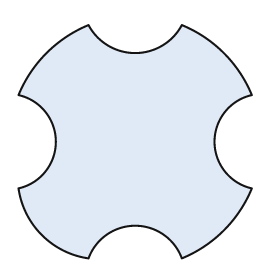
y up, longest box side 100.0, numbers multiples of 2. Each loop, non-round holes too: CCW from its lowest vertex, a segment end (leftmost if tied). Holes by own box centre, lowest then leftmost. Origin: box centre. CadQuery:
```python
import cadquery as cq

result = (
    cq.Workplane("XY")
    .moveTo(-20.0, -50.0)
    .threePointArc((0.0, -36.0), (20.0, -50.0))
    .threePointArc((38.0, -38.0), (50.0, -20.0))
    .threePointArc((34.0, 0.0), (50.0, 20.0))
    .threePointArc((38.0, 38.0), (20.0, 50.0))
    .threePointArc((0.0, 38.0), (-20.0, 50.0))
    .threePointArc((-38.0, 38.0), (-50.0, 20.0))
    .threePointArc((-34.0, 0.0), (-50.0, -20.0))
    .threePointArc((-40.0, -40.0), (-20.0, -50.0))
    .close()
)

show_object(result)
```